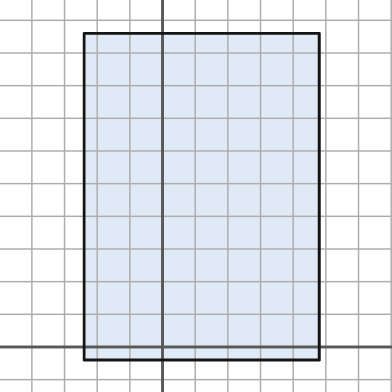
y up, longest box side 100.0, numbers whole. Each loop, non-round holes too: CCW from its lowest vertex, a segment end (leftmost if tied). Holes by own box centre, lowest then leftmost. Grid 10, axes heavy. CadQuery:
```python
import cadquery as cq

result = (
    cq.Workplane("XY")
    .moveTo(-24.0, -4.0)
    .lineTo(48.0, -4.0)
    .lineTo(48.0, 96.0)
    .lineTo(-24.0, 96.0)
    .close()
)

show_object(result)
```